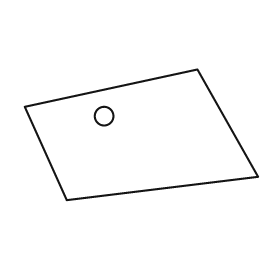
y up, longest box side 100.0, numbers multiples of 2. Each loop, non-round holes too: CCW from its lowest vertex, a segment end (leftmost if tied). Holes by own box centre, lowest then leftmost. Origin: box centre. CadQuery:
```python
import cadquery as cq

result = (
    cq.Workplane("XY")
    .moveTo(-32.0, -28.0)
    .lineTo(50.0, -18.0)
    .lineTo(24.0, 28.0)
    .lineTo(-50.0, 12.0)
    .close()
    .moveTo(-16.0, 8.0)
    .circle(4.0)
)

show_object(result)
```